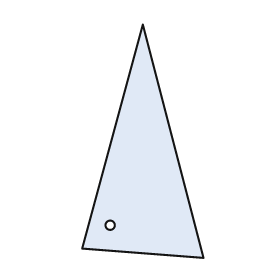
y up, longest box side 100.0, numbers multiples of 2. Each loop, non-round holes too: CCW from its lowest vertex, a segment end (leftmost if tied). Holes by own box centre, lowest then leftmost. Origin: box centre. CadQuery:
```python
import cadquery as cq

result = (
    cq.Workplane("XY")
    .moveTo(26.0, -50.0)
    .lineTo(0.0, 50.0)
    .lineTo(-26.0, -46.0)
    .close()
    .moveTo(-14.0, -36.0)
    .circle(2.0)
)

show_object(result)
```